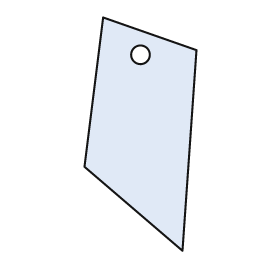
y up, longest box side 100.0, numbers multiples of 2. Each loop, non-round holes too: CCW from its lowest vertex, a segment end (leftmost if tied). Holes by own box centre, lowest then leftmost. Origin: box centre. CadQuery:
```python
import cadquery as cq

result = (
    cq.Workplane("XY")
    .moveTo(18.0, -50.0)
    .lineTo(24.0, 36.0)
    .lineTo(-16.0, 50.0)
    .lineTo(-24.0, -14.0)
    .close()
    .moveTo(0.0, 34.0)
    .circle(4.0)
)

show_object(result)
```